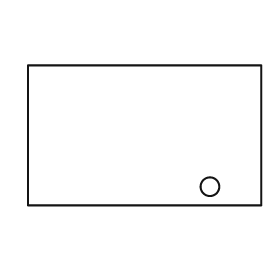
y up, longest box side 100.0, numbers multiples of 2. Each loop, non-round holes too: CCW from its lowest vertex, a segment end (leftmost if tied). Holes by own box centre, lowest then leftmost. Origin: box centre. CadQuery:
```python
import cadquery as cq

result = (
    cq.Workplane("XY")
    .moveTo(-50.0, -30.0)
    .lineTo(50.0, -30.0)
    .lineTo(50.0, 30.0)
    .lineTo(-50.0, 30.0)
    .close()
    .moveTo(28.0, -22.0)
    .circle(4.0)
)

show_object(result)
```